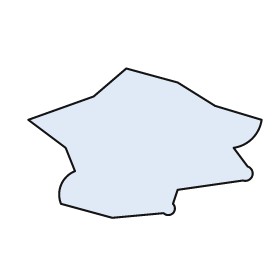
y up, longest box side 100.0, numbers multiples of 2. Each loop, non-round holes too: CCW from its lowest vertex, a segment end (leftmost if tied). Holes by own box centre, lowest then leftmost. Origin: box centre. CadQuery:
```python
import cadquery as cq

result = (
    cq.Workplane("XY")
    .moveTo(-14.0, -32.0)
    .lineTo(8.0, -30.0)
    .threePointArc((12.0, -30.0), (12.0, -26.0))
    .lineTo(14.0, -20.0)
    .lineTo(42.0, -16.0)
    .threePointArc((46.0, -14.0), (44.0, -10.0))
    .lineTo(38.0, -2.0)
    .threePointArc((46.0, 2.0), (50.0, 10.0))
    .lineTo(30.0, 16.0)
    .lineTo(14.0, 26.0)
    .lineTo(-8.0, 32.0)
    .lineTo(-22.0, 20.0)
    .lineTo(-50.0, 10.0)
    .lineTo(-34.0, -2.0)
    .lineTo(-30.0, -12.0)
    .threePointArc((-36.0, -18.0), (-36.0, -26.0))
    .close()
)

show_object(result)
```